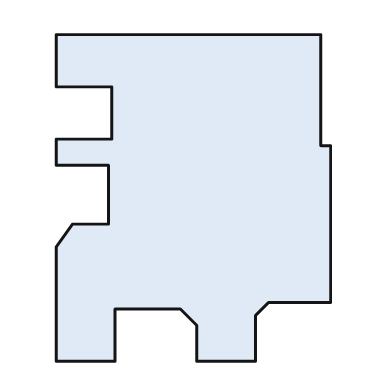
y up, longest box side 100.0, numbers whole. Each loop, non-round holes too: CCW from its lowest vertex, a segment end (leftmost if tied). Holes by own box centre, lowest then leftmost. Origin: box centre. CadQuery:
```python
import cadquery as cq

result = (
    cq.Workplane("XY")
    .moveTo(-42.0, -50.0)
    .lineTo(-24.0, -50.0)
    .lineTo(-24.0, -34.0)
    .lineTo(-4.0, -34.0)
    .lineTo(1.0, -39.0)
    .lineTo(1.0, -50.0)
    .lineTo(19.0, -50.0)
    .lineTo(19.0, -36.0)
    .lineTo(23.0, -32.0)
    .lineTo(42.0, -32.0)
    .lineTo(42.0, 16.0)
    .lineTo(39.0, 16.0)
    .lineTo(39.0, 50.0)
    .lineTo(-42.0, 50.0)
    .lineTo(-42.0, 34.0)
    .lineTo(-25.0, 34.0)
    .lineTo(-25.0, 18.0)
    .lineTo(-42.0, 18.0)
    .lineTo(-42.0, 10.0)
    .lineTo(-26.0, 10.0)
    .lineTo(-26.0, -8.0)
    .lineTo(-37.0, -8.0)
    .lineTo(-42.0, -15.0)
    .close()
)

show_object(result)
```